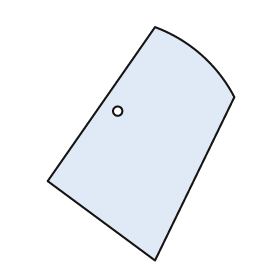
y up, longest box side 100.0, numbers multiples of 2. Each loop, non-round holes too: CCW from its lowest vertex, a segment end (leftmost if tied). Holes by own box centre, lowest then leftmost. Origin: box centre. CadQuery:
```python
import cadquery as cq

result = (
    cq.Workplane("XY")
    .moveTo(6.0, -50.0)
    .lineTo(40.0, 20.0)
    .threePointArc((26.0, 38.0), (6.0, 50.0))
    .lineTo(-40.0, -16.0)
    .close()
    .moveTo(-10.0, 14.0)
    .circle(2.0)
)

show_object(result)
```